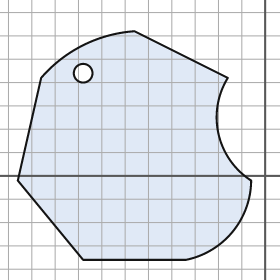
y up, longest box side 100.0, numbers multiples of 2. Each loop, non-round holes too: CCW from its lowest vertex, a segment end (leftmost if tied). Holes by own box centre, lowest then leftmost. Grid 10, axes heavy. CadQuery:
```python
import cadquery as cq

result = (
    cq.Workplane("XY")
    .moveTo(-78.0, -36.0)
    .lineTo(-34.0, -36.0)
    .threePointArc((-14.0, -24.0), (-6.0, -2.0))
    .threePointArc((-20.0, 18.0), (-16.0, 42.0))
    .lineTo(-56.0, 62.0)
    .threePointArc((-78.0, 56.0), (-96.0, 42.0))
    .lineTo(-106.0, -2.0)
    .close()
    .moveTo(-78.0, 44.0)
    .circle(4.0)
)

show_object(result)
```